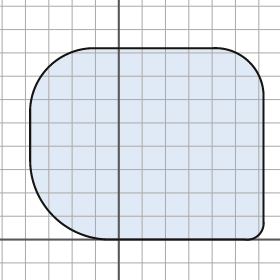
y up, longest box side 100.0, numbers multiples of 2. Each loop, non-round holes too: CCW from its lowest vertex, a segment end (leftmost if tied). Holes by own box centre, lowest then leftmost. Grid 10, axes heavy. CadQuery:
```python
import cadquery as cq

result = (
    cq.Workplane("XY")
    .moveTo(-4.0, 0.0)
    .lineTo(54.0, 0.0)
    .threePointArc((60.0, 2.0), (62.0, 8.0))
    .lineTo(62.0, 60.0)
    .threePointArc((56.0, 76.0), (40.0, 82.0))
    .lineTo(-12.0, 82.0)
    .threePointArc((-30.0, 74.0), (-38.0, 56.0))
    .lineTo(-38.0, 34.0)
    .threePointArc((-28.0, 10.0), (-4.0, 0.0))
    .close()
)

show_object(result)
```